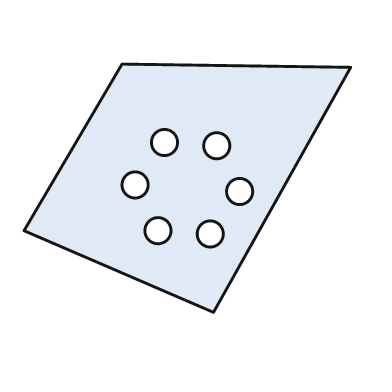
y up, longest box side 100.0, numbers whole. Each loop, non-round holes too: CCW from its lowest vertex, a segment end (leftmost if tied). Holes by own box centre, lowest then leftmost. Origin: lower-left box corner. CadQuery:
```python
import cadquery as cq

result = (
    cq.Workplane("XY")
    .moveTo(58.0, 0.0)
    .lineTo(100.0, 75.0)
    .lineTo(30.0, 76.0)
    .lineTo(0.0, 25.0)
    .close()
    .moveTo(57.0, 24.0)
    .circle(4.0)
    .moveTo(41.0, 25.0)
    .circle(4.0)
    .moveTo(66.0, 37.0)
    .circle(4.0)
    .moveTo(34.0, 39.0)
    .circle(4.0)
    .moveTo(59.0, 51.0)
    .circle(4.0)
    .moveTo(43.0, 52.0)
    .circle(4.0)
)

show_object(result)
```